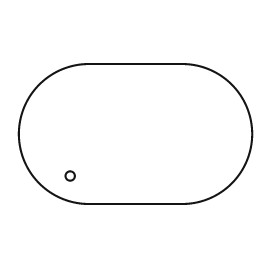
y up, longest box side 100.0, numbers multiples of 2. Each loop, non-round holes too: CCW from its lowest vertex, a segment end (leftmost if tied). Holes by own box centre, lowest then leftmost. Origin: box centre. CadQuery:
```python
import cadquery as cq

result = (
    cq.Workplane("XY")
    .moveTo(-20.0, -30.0)
    .lineTo(20.0, -30.0)
    .threePointArc((50.0, 0.0), (20.0, 30.0))
    .lineTo(-20.0, 30.0)
    .threePointArc((-50.0, 0.0), (-20.0, -30.0))
    .close()
    .moveTo(-28.0, -18.0)
    .circle(2.0)
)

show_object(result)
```